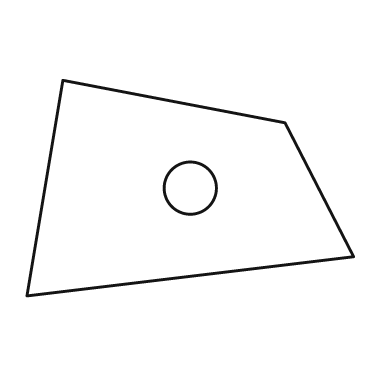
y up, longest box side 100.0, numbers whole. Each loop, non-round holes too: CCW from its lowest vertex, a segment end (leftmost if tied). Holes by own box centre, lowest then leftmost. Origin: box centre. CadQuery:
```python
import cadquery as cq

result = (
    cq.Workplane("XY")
    .moveTo(-50.0, -33.0)
    .lineTo(50.0, -21.0)
    .lineTo(29.0, 20.0)
    .lineTo(-39.0, 33.0)
    .close()
    .moveTo(0.0, 0.0)
    .circle(8.0)
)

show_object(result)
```